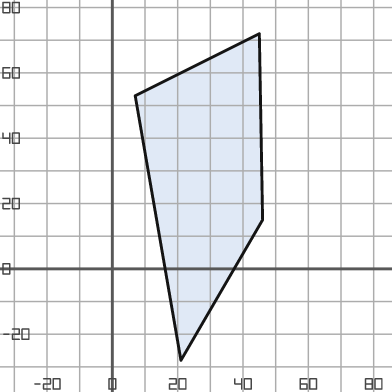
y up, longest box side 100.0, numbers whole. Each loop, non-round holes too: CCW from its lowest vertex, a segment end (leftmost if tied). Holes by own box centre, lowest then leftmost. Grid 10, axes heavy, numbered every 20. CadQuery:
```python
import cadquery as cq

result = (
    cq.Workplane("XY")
    .moveTo(21.0, -28.0)
    .lineTo(46.0, 15.0)
    .lineTo(45.0, 72.0)
    .lineTo(7.0, 53.0)
    .close()
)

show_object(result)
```